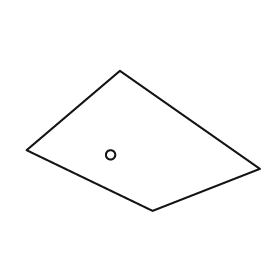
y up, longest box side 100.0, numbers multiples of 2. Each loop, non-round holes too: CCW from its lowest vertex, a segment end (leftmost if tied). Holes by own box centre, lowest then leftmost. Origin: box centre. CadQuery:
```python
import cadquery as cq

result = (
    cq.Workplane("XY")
    .moveTo(4.0, -30.0)
    .lineTo(50.0, -12.0)
    .lineTo(-10.0, 30.0)
    .lineTo(-50.0, -4.0)
    .close()
    .moveTo(-14.0, -6.0)
    .circle(2.0)
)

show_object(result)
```